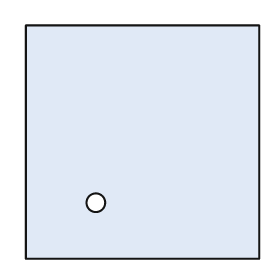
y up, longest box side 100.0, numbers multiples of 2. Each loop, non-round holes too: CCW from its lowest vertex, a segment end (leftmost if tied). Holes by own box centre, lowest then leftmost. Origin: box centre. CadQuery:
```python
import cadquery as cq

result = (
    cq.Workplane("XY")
    .moveTo(-50.0, -50.0)
    .lineTo(50.0, -50.0)
    .lineTo(50.0, 50.0)
    .lineTo(-50.0, 50.0)
    .close()
    .moveTo(-20.0, -26.0)
    .circle(4.0)
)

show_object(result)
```